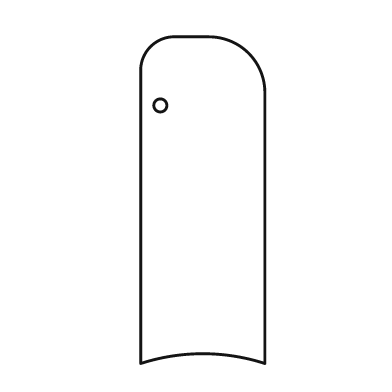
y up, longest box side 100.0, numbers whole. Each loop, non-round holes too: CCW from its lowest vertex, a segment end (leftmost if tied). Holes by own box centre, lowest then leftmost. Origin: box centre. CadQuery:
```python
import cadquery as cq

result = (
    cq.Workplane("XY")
    .moveTo(-19.0, -50.0)
    .threePointArc((0.0, -47.0), (19.0, -50.0))
    .lineTo(19.0, 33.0)
    .threePointArc((14.0, 45.0), (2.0, 50.0))
    .lineTo(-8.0, 50.0)
    .threePointArc((-16.0, 47.0), (-19.0, 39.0))
    .close()
    .moveTo(-13.0, 29.0)
    .circle(2.0)
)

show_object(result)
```